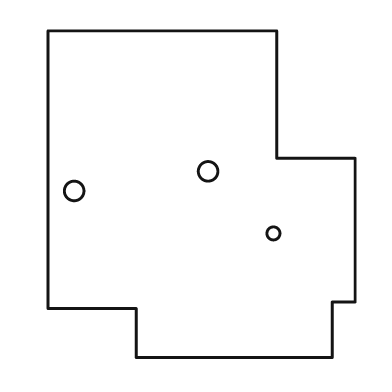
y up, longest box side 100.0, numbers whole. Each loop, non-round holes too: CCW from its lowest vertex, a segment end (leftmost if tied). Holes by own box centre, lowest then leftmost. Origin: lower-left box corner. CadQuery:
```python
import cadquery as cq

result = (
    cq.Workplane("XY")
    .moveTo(27.0, 0.0)
    .lineTo(87.0, 0.0)
    .lineTo(87.0, 17.0)
    .lineTo(94.0, 17.0)
    .lineTo(94.0, 61.0)
    .lineTo(70.0, 61.0)
    .lineTo(70.0, 100.0)
    .lineTo(0.0, 100.0)
    .lineTo(0.0, 15.0)
    .lineTo(27.0, 15.0)
    .close()
    .moveTo(69.0, 38.0)
    .circle(2.0)
    .moveTo(8.0, 51.0)
    .circle(3.0)
    .moveTo(49.0, 57.0)
    .circle(3.0)
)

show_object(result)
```